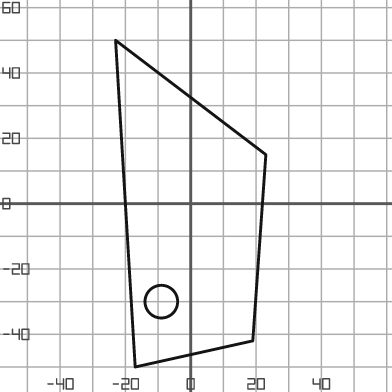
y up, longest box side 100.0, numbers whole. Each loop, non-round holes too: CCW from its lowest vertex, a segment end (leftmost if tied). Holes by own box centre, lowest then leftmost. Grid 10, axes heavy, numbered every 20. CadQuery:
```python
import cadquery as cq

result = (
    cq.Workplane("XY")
    .moveTo(-17.0, -50.0)
    .lineTo(19.0, -42.0)
    .lineTo(23.0, 15.0)
    .lineTo(-23.0, 50.0)
    .close()
    .moveTo(-9.0, -30.0)
    .circle(5.0)
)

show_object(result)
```